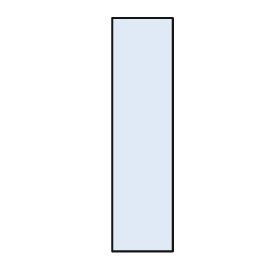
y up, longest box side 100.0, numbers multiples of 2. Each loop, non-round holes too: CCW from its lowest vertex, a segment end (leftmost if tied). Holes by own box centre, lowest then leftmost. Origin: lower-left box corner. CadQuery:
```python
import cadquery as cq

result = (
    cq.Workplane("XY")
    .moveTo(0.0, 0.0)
    .lineTo(26.0, 0.0)
    .lineTo(26.0, 100.0)
    .lineTo(0.0, 100.0)
    .close()
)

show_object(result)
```